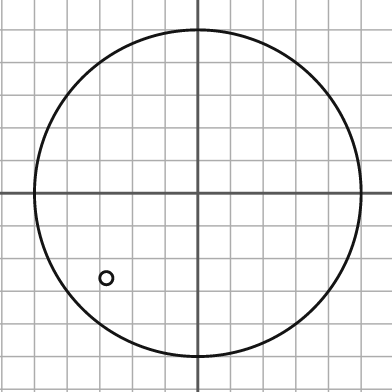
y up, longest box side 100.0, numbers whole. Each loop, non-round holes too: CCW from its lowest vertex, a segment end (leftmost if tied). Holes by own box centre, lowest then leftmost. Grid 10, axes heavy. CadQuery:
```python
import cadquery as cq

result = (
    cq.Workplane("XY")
    .moveTo(0.0, 0.0)
    .circle(50.0)
    .moveTo(-28.0, -26.0)
    .circle(2.0)
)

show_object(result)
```